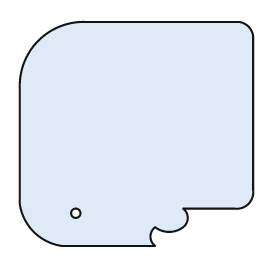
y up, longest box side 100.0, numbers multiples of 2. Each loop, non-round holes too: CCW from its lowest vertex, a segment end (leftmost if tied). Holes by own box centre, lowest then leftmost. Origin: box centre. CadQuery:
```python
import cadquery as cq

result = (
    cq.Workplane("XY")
    .moveTo(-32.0, -48.0)
    .lineTo(8.0, -48.0)
    .threePointArc((6.0, -44.0), (8.0, -40.0))
    .threePointArc((14.0, -42.0), (20.0, -40.0))
    .threePointArc((22.0, -36.0), (20.0, -32.0))
    .lineTo(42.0, -32.0)
    .threePointArc((48.0, -30.0), (50.0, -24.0))
    .lineTo(50.0, 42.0)
    .threePointArc((48.0, 46.0), (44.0, 48.0))
    .lineTo(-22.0, 48.0)
    .threePointArc((-42.0, 40.0), (-50.0, 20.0))
    .lineTo(-50.0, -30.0)
    .threePointArc((-44.0, -42.0), (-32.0, -48.0))
    .close()
    .moveTo(-26.0, -34.0)
    .circle(2.0)
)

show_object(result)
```